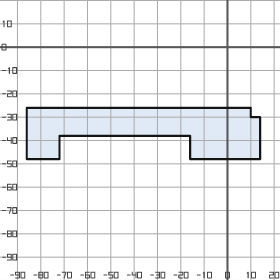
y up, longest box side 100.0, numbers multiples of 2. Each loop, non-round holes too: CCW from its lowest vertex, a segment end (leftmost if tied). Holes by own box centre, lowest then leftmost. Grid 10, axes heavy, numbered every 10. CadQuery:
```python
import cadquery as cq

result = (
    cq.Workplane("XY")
    .moveTo(-86.0, -48.0)
    .lineTo(-72.0, -48.0)
    .lineTo(-72.0, -38.0)
    .lineTo(-16.0, -38.0)
    .lineTo(-16.0, -48.0)
    .lineTo(14.0, -48.0)
    .lineTo(14.0, -30.0)
    .lineTo(10.0, -30.0)
    .lineTo(10.0, -26.0)
    .lineTo(-86.0, -26.0)
    .close()
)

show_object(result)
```